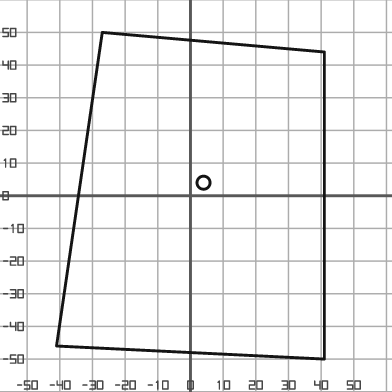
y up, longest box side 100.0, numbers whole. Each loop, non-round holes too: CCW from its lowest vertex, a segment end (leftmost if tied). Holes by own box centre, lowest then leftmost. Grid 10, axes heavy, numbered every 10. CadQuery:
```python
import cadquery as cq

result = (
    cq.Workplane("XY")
    .moveTo(41.0, -50.0)
    .lineTo(41.0, 44.0)
    .lineTo(-27.0, 50.0)
    .lineTo(-41.0, -46.0)
    .close()
    .moveTo(4.0, 4.0)
    .circle(2.0)
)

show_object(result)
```